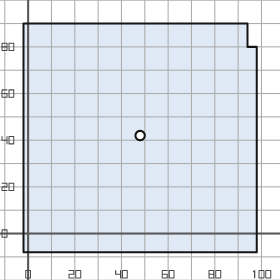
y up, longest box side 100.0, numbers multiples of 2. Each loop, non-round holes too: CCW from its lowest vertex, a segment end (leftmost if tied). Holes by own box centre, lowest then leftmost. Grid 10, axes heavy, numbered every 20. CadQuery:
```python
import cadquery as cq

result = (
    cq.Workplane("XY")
    .moveTo(-2.0, -8.0)
    .lineTo(98.0, -8.0)
    .lineTo(98.0, 80.0)
    .lineTo(94.0, 80.0)
    .lineTo(94.0, 90.0)
    .lineTo(-2.0, 90.0)
    .close()
    .moveTo(48.0, 42.0)
    .circle(2.0)
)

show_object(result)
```